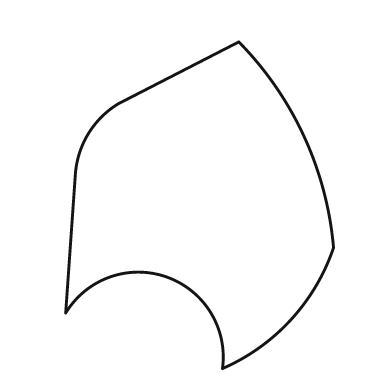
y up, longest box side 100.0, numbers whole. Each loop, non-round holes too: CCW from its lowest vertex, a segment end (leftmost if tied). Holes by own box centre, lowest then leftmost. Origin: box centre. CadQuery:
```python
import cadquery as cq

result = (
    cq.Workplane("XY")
    .moveTo(7.0, -50.0)
    .threePointArc((28.0, -35.0), (41.0, -13.0))
    .threePointArc((32.0, 21.0), (12.0, 50.0))
    .lineTo(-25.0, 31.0)
    .threePointArc((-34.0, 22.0), (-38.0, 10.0))
    .lineTo(-41.0, -33.0)
    .threePointArc((-10.0, -22.0), (7.0, -50.0))
    .close()
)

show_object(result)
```